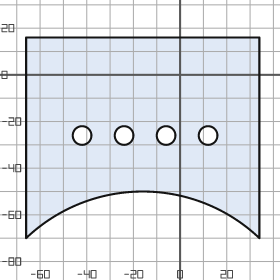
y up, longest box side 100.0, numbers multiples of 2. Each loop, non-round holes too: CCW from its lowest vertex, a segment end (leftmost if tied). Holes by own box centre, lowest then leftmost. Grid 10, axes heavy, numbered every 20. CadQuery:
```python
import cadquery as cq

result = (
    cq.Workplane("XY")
    .moveTo(-66.0, -70.0)
    .threePointArc((-16.0, -50.0), (34.0, -70.0))
    .lineTo(34.0, 16.0)
    .lineTo(-66.0, 16.0)
    .close()
    .moveTo(-42.0, -26.0)
    .circle(4.0)
    .moveTo(-24.0, -26.0)
    .circle(4.0)
    .moveTo(-6.0, -26.0)
    .circle(4.0)
    .moveTo(12.0, -26.0)
    .circle(4.0)
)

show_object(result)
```